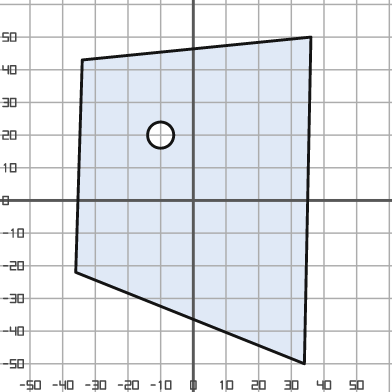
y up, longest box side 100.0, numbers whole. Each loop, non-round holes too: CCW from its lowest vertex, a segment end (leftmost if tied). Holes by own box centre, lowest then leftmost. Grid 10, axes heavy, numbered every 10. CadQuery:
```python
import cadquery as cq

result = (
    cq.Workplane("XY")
    .moveTo(34.0, -50.0)
    .lineTo(36.0, 50.0)
    .lineTo(-34.0, 43.0)
    .lineTo(-36.0, -22.0)
    .close()
    .moveTo(-10.0, 20.0)
    .circle(4.0)
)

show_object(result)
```